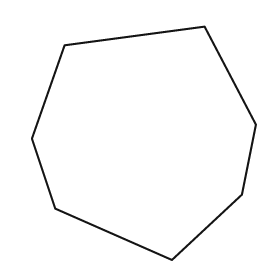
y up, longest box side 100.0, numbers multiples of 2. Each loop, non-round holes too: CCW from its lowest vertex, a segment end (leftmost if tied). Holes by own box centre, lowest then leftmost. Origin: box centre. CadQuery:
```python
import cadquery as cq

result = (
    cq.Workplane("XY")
    .moveTo(12.0, -50.0)
    .lineTo(42.0, -22.0)
    .lineTo(48.0, 8.0)
    .lineTo(26.0, 50.0)
    .lineTo(-34.0, 42.0)
    .lineTo(-48.0, 2.0)
    .lineTo(-38.0, -28.0)
    .close()
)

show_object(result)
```